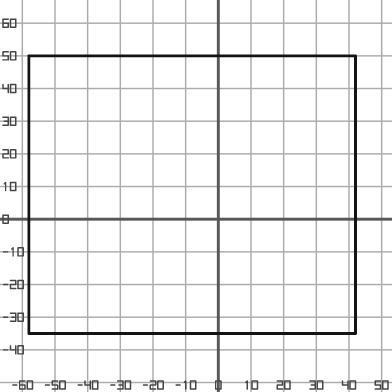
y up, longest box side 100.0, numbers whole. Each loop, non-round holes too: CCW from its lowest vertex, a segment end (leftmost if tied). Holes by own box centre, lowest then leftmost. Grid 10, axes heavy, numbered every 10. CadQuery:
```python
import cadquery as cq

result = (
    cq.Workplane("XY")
    .moveTo(-58.0, -35.0)
    .lineTo(42.0, -35.0)
    .lineTo(42.0, 50.0)
    .lineTo(-58.0, 50.0)
    .close()
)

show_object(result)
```